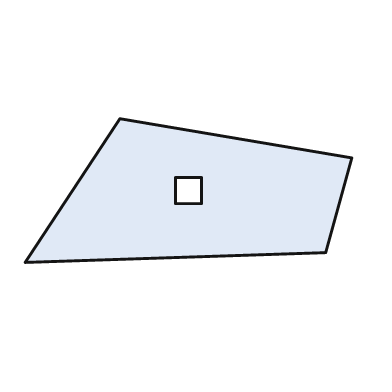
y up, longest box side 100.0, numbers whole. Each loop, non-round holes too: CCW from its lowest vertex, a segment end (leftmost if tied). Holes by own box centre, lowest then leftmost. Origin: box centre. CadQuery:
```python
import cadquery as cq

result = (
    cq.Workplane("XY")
    .moveTo(-50.0, -22.0)
    .lineTo(42.0, -19.0)
    .lineTo(50.0, 10.0)
    .lineTo(-21.0, 22.0)
    .close()
    .moveTo(-4.0, -4.0)
    .lineTo(4.0, -4.0)
    .lineTo(4.0, 4.0)
    .lineTo(-4.0, 4.0)
    .close()
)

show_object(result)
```